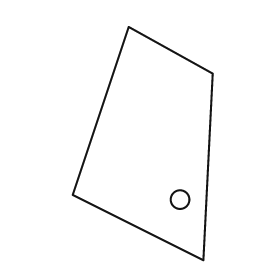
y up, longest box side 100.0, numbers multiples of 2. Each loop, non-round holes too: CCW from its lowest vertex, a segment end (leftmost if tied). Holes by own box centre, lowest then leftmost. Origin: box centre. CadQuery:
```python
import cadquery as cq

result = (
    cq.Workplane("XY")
    .moveTo(26.0, -50.0)
    .lineTo(30.0, 30.0)
    .lineTo(-6.0, 50.0)
    .lineTo(-30.0, -22.0)
    .close()
    .moveTo(16.0, -24.0)
    .circle(4.0)
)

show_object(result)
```